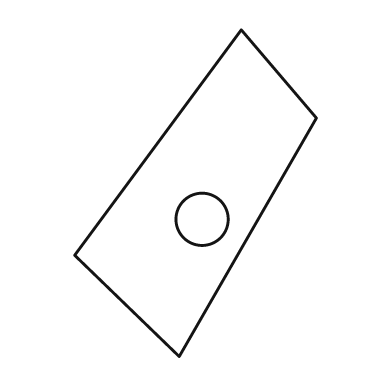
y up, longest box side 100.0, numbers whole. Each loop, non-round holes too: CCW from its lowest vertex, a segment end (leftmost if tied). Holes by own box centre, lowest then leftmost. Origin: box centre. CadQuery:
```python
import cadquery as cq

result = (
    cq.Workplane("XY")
    .moveTo(-5.0, -50.0)
    .lineTo(37.0, 23.0)
    .lineTo(14.0, 50.0)
    .lineTo(-37.0, -19.0)
    .close()
    .moveTo(2.0, -8.0)
    .circle(8.0)
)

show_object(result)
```